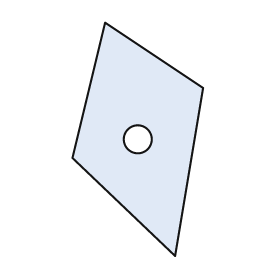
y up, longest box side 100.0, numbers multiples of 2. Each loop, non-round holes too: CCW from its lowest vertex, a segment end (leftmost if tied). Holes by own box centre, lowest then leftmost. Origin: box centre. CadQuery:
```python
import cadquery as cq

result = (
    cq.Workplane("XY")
    .moveTo(16.0, -50.0)
    .lineTo(28.0, 22.0)
    .lineTo(-14.0, 50.0)
    .lineTo(-28.0, -8.0)
    .close()
    .moveTo(0.0, 0.0)
    .circle(6.0)
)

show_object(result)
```